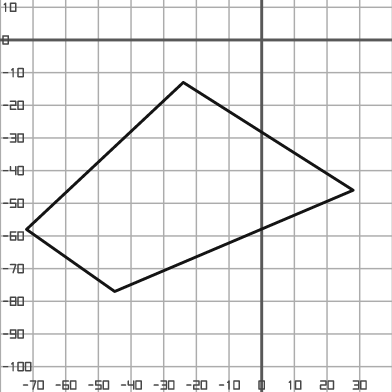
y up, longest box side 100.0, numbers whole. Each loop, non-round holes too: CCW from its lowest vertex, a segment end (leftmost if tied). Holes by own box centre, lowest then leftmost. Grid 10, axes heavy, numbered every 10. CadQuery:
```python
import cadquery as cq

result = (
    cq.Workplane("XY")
    .moveTo(-45.0, -77.0)
    .lineTo(28.0, -46.0)
    .lineTo(-24.0, -13.0)
    .lineTo(-72.0, -58.0)
    .close()
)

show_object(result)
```